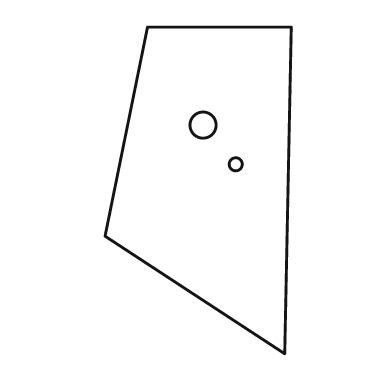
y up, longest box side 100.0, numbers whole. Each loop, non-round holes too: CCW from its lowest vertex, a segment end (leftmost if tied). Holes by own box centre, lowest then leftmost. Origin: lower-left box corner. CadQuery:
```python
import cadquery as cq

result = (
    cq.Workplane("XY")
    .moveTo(55.0, 0.0)
    .lineTo(57.0, 100.0)
    .lineTo(13.0, 100.0)
    .lineTo(0.0, 36.0)
    .close()
    .moveTo(40.0, 58.0)
    .circle(2.0)
    .moveTo(30.0, 70.0)
    .circle(4.0)
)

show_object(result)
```